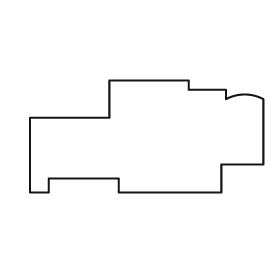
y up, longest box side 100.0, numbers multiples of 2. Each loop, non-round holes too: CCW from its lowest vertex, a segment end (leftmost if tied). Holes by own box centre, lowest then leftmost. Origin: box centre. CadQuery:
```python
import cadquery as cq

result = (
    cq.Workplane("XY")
    .moveTo(-50.0, -24.0)
    .lineTo(-42.0, -24.0)
    .lineTo(-42.0, -18.0)
    .lineTo(-12.0, -18.0)
    .lineTo(-12.0, -24.0)
    .lineTo(32.0, -24.0)
    .lineTo(32.0, -12.0)
    .lineTo(50.0, -12.0)
    .lineTo(50.0, 16.0)
    .threePointArc((42.0, 18.0), (34.0, 16.0))
    .lineTo(34.0, 20.0)
    .lineTo(18.0, 20.0)
    .lineTo(18.0, 24.0)
    .lineTo(-16.0, 24.0)
    .lineTo(-16.0, 8.0)
    .lineTo(-50.0, 8.0)
    .close()
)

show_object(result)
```